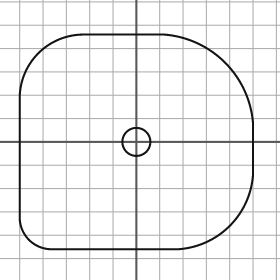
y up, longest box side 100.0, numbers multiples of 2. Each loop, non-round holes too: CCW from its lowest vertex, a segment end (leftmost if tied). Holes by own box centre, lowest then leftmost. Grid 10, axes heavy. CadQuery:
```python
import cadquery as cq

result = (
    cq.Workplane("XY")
    .moveTo(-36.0, -46.0)
    .lineTo(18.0, -46.0)
    .threePointArc((40.0, -36.0), (50.0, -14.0))
    .lineTo(50.0, 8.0)
    .threePointArc((38.0, 34.0), (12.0, 46.0))
    .lineTo(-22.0, 46.0)
    .threePointArc((-42.0, 38.0), (-50.0, 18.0))
    .lineTo(-50.0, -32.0)
    .threePointArc((-46.0, -42.0), (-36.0, -46.0))
    .close()
    .moveTo(0.0, 0.0)
    .circle(6.0)
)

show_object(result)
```